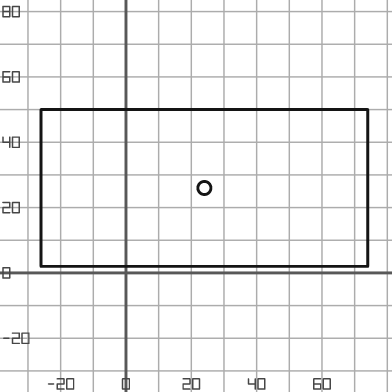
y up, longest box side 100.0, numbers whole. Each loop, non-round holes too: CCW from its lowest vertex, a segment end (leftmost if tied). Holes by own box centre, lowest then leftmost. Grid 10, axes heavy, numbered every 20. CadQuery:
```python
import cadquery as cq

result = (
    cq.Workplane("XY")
    .moveTo(-26.0, 2.0)
    .lineTo(74.0, 2.0)
    .lineTo(74.0, 50.0)
    .lineTo(-26.0, 50.0)
    .close()
    .moveTo(24.0, 26.0)
    .circle(2.0)
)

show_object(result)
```